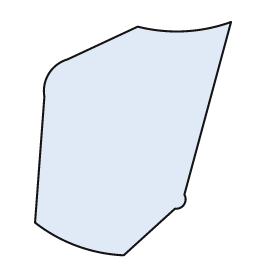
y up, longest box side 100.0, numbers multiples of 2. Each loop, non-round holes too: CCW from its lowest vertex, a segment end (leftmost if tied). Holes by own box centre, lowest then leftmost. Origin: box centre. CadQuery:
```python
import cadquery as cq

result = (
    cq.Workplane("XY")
    .moveTo(-4.0, -50.0)
    .lineTo(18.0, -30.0)
    .threePointArc((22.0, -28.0), (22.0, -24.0))
    .lineTo(42.0, 50.0)
    .threePointArc((22.0, 46.0), (2.0, 48.0))
    .lineTo(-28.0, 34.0)
    .threePointArc((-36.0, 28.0), (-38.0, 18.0))
    .lineTo(-42.0, -36.0)
    .threePointArc((-24.0, -46.0), (-4.0, -50.0))
    .close()
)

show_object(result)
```